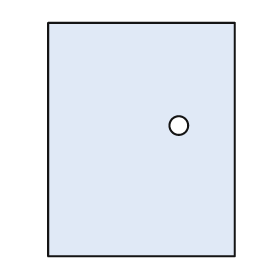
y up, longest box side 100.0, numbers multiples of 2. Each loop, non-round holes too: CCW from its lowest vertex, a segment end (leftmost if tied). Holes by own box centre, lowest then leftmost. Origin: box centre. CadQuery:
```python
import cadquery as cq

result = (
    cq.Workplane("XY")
    .moveTo(-40.0, -50.0)
    .lineTo(40.0, -50.0)
    .lineTo(40.0, 50.0)
    .lineTo(-40.0, 50.0)
    .close()
    .moveTo(16.0, 6.0)
    .circle(4.0)
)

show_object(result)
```